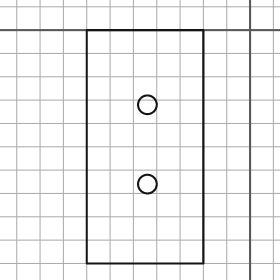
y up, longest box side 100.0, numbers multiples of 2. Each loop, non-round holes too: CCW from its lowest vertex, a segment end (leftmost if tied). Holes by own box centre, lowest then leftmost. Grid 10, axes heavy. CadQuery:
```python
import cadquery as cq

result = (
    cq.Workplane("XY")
    .moveTo(-70.0, -100.0)
    .lineTo(-20.0, -100.0)
    .lineTo(-20.0, 0.0)
    .lineTo(-70.0, 0.0)
    .close()
    .moveTo(-44.0, -66.0)
    .circle(4.0)
    .moveTo(-44.0, -32.0)
    .circle(4.0)
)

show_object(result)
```